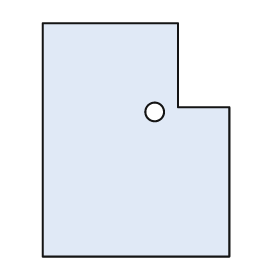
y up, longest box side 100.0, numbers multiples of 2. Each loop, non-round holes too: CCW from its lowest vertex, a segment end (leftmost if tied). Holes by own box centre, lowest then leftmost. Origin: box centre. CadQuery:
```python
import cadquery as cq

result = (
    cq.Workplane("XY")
    .moveTo(-40.0, -50.0)
    .lineTo(40.0, -50.0)
    .lineTo(40.0, 14.0)
    .lineTo(18.0, 14.0)
    .lineTo(18.0, 50.0)
    .lineTo(-40.0, 50.0)
    .close()
    .moveTo(8.0, 12.0)
    .circle(4.0)
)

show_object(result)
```